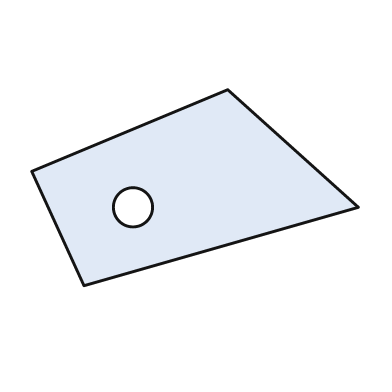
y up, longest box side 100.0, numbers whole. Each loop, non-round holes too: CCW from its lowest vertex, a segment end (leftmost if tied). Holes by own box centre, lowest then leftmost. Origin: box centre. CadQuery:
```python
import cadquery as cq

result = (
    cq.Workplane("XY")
    .moveTo(-34.0, -30.0)
    .lineTo(50.0, -6.0)
    .lineTo(10.0, 30.0)
    .lineTo(-50.0, 5.0)
    .close()
    .moveTo(-19.0, -6.0)
    .circle(6.0)
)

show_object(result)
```